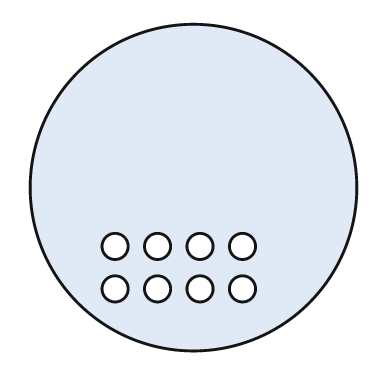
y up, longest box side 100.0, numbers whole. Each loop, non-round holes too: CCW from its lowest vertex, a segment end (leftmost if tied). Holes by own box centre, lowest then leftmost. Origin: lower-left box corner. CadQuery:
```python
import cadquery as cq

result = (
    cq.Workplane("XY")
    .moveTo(50.0, 50.0)
    .circle(50.0)
    .moveTo(26.0, 19.0)
    .circle(4.0)
    .moveTo(39.0, 19.0)
    .circle(4.0)
    .moveTo(52.0, 19.0)
    .circle(4.0)
    .moveTo(65.0, 19.0)
    .circle(4.0)
    .moveTo(26.0, 32.0)
    .circle(4.0)
    .moveTo(39.0, 32.0)
    .circle(4.0)
    .moveTo(52.0, 32.0)
    .circle(4.0)
    .moveTo(65.0, 32.0)
    .circle(4.0)
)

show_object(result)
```